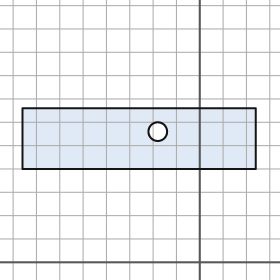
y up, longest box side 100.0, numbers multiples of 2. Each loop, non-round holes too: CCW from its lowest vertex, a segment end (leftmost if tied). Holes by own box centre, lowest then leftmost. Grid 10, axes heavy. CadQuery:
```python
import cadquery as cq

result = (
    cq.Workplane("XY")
    .moveTo(-76.0, 40.0)
    .lineTo(24.0, 40.0)
    .lineTo(24.0, 66.0)
    .lineTo(-76.0, 66.0)
    .close()
    .moveTo(-18.0, 56.0)
    .circle(4.0)
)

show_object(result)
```